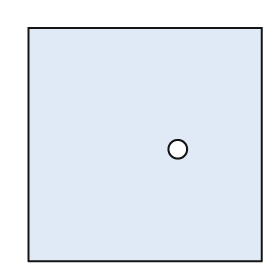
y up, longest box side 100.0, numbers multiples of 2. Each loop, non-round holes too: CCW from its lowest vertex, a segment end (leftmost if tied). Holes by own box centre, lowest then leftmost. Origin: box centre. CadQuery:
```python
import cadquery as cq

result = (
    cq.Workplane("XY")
    .moveTo(-50.0, -50.0)
    .lineTo(50.0, -50.0)
    .lineTo(50.0, 50.0)
    .lineTo(-50.0, 50.0)
    .close()
    .moveTo(14.0, -2.0)
    .circle(4.0)
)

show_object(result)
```